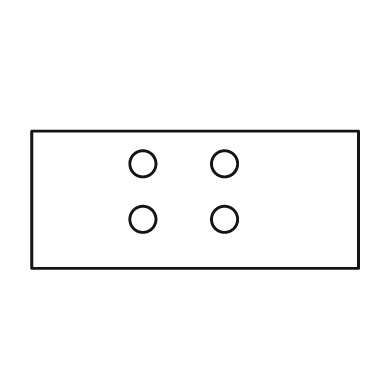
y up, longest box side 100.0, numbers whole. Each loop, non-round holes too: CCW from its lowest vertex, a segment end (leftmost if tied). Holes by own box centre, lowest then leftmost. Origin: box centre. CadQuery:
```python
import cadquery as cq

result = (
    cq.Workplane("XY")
    .moveTo(-50.0, -21.0)
    .lineTo(50.0, -21.0)
    .lineTo(50.0, 21.0)
    .lineTo(-50.0, 21.0)
    .close()
    .moveTo(-16.0, -6.0)
    .circle(4.0)
    .moveTo(9.0, -6.0)
    .circle(4.0)
    .moveTo(-16.0, 11.0)
    .circle(4.0)
    .moveTo(9.0, 11.0)
    .circle(4.0)
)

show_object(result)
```